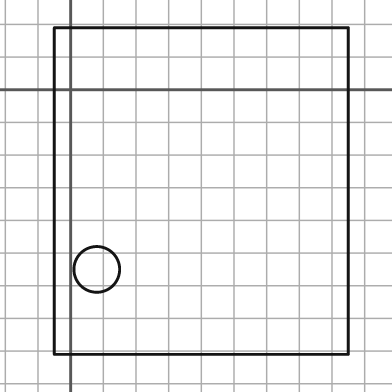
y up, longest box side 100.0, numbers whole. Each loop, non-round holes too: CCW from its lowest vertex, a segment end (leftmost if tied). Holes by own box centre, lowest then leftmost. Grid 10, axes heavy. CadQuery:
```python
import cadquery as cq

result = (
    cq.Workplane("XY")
    .moveTo(-5.0, -81.0)
    .lineTo(85.0, -81.0)
    .lineTo(85.0, 19.0)
    .lineTo(-5.0, 19.0)
    .close()
    .moveTo(8.0, -55.0)
    .circle(7.0)
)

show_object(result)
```